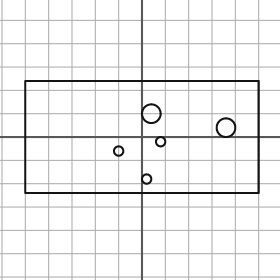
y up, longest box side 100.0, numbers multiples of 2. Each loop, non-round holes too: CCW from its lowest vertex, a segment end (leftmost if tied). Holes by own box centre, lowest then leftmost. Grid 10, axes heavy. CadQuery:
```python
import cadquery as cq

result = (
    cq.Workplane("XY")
    .moveTo(-50.0, -24.0)
    .lineTo(50.0, -24.0)
    .lineTo(50.0, 24.0)
    .lineTo(-50.0, 24.0)
    .close()
    .moveTo(2.0, -18.0)
    .circle(2.0)
    .moveTo(-10.0, -6.0)
    .circle(2.0)
    .moveTo(8.0, -2.0)
    .circle(2.0)
    .moveTo(36.0, 4.0)
    .circle(4.0)
    .moveTo(4.0, 10.0)
    .circle(4.0)
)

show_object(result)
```